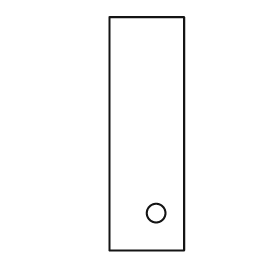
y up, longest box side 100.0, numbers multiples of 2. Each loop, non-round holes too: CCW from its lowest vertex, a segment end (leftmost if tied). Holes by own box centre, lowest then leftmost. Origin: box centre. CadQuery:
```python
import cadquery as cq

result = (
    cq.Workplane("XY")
    .moveTo(-16.0, -50.0)
    .lineTo(16.0, -50.0)
    .lineTo(16.0, 50.0)
    .lineTo(-16.0, 50.0)
    .close()
    .moveTo(4.0, -34.0)
    .circle(4.0)
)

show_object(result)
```